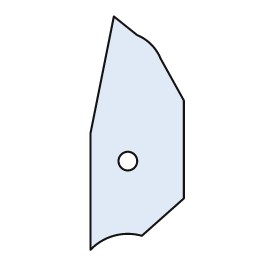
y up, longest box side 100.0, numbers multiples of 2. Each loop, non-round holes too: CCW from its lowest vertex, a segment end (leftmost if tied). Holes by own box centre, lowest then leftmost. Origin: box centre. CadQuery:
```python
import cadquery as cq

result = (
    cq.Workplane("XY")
    .moveTo(-20.0, -50.0)
    .threePointArc((-10.0, -44.0), (2.0, -44.0))
    .lineTo(20.0, -28.0)
    .lineTo(20.0, 14.0)
    .lineTo(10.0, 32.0)
    .threePointArc((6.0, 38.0), (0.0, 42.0))
    .lineTo(-10.0, 50.0)
    .lineTo(-20.0, 0.0)
    .close()
    .moveTo(-4.0, -12.0)
    .circle(4.0)
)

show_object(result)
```